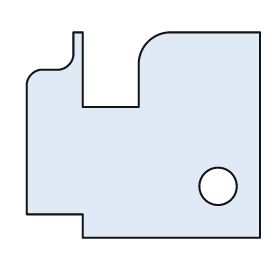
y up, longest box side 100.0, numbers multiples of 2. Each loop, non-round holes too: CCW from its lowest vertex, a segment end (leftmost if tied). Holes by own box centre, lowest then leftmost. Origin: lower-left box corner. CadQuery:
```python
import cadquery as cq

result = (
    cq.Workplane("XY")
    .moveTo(24.0, 0.0)
    .lineTo(100.0, 0.0)
    .lineTo(100.0, 88.0)
    .lineTo(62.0, 88.0)
    .threePointArc((52.0, 84.0), (48.0, 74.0))
    .lineTo(48.0, 56.0)
    .lineTo(24.0, 56.0)
    .lineTo(24.0, 88.0)
    .lineTo(20.0, 88.0)
    .lineTo(20.0, 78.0)
    .threePointArc((18.0, 74.0), (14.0, 72.0))
    .lineTo(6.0, 72.0)
    .threePointArc((2.0, 70.0), (0.0, 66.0))
    .lineTo(0.0, 10.0)
    .lineTo(24.0, 10.0)
    .close()
    .moveTo(82.0, 22.0)
    .circle(8.0)
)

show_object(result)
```